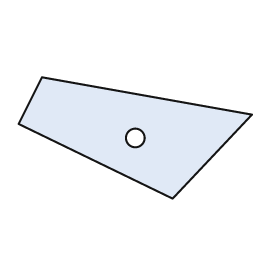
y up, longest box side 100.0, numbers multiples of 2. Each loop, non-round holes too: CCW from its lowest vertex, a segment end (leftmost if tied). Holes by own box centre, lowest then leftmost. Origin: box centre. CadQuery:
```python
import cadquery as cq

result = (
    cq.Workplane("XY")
    .moveTo(16.0, -26.0)
    .lineTo(50.0, 10.0)
    .lineTo(-40.0, 26.0)
    .lineTo(-50.0, 6.0)
    .close()
    .moveTo(0.0, 0.0)
    .circle(4.0)
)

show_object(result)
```